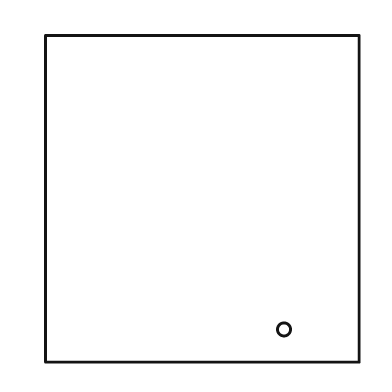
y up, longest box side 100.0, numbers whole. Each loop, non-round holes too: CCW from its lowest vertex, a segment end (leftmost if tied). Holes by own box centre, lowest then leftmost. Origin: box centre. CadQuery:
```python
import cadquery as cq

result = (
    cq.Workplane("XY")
    .moveTo(-48.0, -50.0)
    .lineTo(48.0, -50.0)
    .lineTo(48.0, 50.0)
    .lineTo(-48.0, 50.0)
    .close()
    .moveTo(25.0, -40.0)
    .circle(2.0)
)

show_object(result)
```